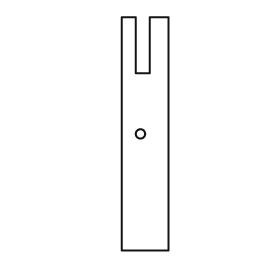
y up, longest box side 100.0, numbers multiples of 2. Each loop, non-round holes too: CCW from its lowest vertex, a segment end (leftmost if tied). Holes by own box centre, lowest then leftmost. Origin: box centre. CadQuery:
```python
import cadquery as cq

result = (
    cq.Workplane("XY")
    .moveTo(-10.0, -50.0)
    .lineTo(10.0, -50.0)
    .lineTo(10.0, 50.0)
    .lineTo(2.0, 50.0)
    .lineTo(2.0, 26.0)
    .lineTo(-4.0, 26.0)
    .lineTo(-4.0, 50.0)
    .lineTo(-10.0, 50.0)
    .close()
    .moveTo(-2.0, 0.0)
    .circle(2.0)
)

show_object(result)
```